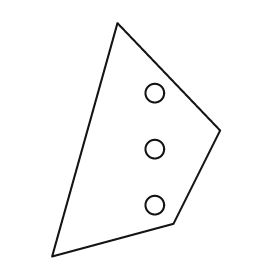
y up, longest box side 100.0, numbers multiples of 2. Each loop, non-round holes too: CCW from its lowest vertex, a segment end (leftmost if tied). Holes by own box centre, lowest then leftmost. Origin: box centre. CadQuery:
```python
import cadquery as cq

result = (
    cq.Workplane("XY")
    .moveTo(-36.0, -50.0)
    .lineTo(16.0, -36.0)
    .lineTo(36.0, 4.0)
    .lineTo(-8.0, 50.0)
    .close()
    .moveTo(8.0, -28.0)
    .circle(4.0)
    .moveTo(8.0, -4.0)
    .circle(4.0)
    .moveTo(8.0, 20.0)
    .circle(4.0)
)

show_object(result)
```